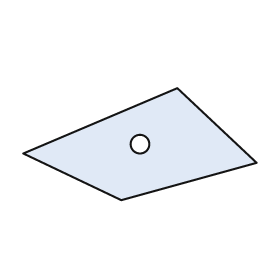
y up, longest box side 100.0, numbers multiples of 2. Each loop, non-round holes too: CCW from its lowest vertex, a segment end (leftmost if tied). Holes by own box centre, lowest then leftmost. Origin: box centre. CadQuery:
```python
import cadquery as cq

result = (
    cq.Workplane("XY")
    .moveTo(-8.0, -24.0)
    .lineTo(50.0, -8.0)
    .lineTo(16.0, 24.0)
    .lineTo(-50.0, -4.0)
    .close()
    .moveTo(0.0, 0.0)
    .circle(4.0)
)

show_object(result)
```